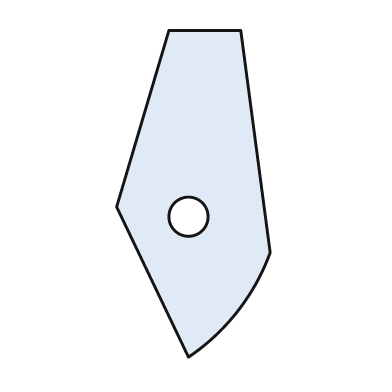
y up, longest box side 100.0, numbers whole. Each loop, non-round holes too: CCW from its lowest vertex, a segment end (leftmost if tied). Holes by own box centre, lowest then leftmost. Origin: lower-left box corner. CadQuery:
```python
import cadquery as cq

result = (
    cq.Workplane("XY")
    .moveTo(22.0, 0.0)
    .threePointArc((37.0, 14.0), (47.0, 32.0))
    .lineTo(38.0, 100.0)
    .lineTo(16.0, 100.0)
    .lineTo(0.0, 46.0)
    .close()
    .moveTo(22.0, 43.0)
    .circle(6.0)
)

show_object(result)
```